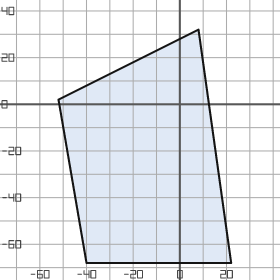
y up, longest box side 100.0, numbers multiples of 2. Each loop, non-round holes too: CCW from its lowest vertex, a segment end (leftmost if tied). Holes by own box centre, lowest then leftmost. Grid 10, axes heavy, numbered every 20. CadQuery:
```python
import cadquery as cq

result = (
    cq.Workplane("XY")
    .moveTo(-40.0, -68.0)
    .lineTo(22.0, -68.0)
    .lineTo(8.0, 32.0)
    .lineTo(-52.0, 2.0)
    .close()
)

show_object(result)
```